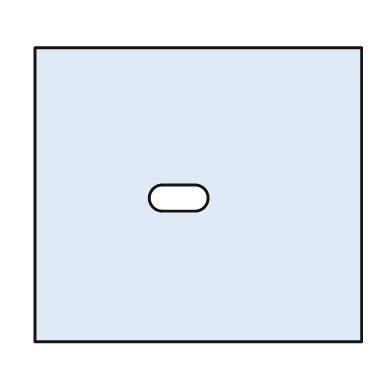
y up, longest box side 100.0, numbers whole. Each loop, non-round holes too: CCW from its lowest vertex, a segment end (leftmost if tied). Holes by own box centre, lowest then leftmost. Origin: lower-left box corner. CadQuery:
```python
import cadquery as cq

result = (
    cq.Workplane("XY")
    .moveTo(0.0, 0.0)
    .lineTo(100.0, 0.0)
    .lineTo(100.0, 90.0)
    .lineTo(0.0, 90.0)
    .close()
    .moveTo(39.0, 40.0)
    .lineTo(49.0, 40.0)
    .threePointArc((53.0, 44.0), (49.0, 48.0))
    .lineTo(39.0, 48.0)
    .threePointArc((35.0, 44.0), (39.0, 40.0))
    .close()
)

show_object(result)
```